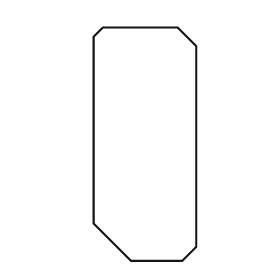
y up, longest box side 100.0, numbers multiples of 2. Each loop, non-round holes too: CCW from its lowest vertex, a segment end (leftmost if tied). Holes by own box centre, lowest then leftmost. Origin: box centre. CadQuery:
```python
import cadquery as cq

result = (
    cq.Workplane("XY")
    .moveTo(-6.0, -50.0)
    .lineTo(16.0, -50.0)
    .lineTo(22.0, -44.0)
    .lineTo(22.0, 42.0)
    .lineTo(14.0, 50.0)
    .lineTo(-18.0, 50.0)
    .lineTo(-22.0, 46.0)
    .lineTo(-22.0, -34.0)
    .close()
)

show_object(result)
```